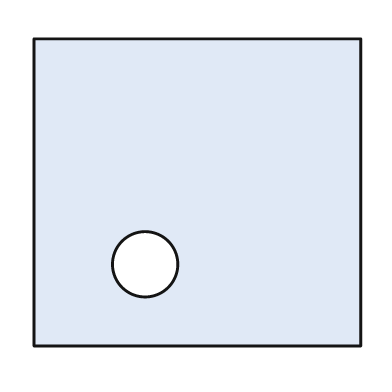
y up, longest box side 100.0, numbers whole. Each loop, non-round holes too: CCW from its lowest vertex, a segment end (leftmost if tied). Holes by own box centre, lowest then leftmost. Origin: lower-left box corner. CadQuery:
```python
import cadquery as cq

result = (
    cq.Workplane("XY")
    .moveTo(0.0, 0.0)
    .lineTo(100.0, 0.0)
    .lineTo(100.0, 94.0)
    .lineTo(0.0, 94.0)
    .close()
    .moveTo(34.0, 25.0)
    .circle(10.0)
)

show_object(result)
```